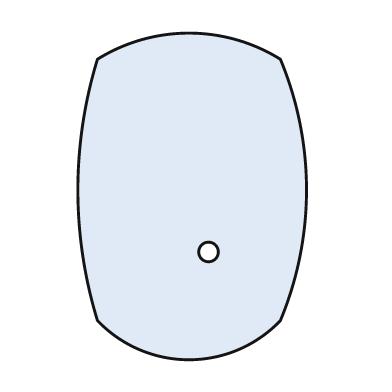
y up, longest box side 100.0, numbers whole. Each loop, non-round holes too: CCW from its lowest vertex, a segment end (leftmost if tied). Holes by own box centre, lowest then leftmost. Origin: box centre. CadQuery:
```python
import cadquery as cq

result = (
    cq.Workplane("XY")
    .moveTo(-29.0, -38.0)
    .threePointArc((-1.0, -50.0), (27.0, -38.0))
    .threePointArc((35.0, 2.0), (27.0, 42.0))
    .threePointArc((-1.0, 50.0), (-29.0, 42.0))
    .threePointArc((-35.0, 2.0), (-29.0, -38.0))
    .close()
    .moveTo(5.0, -17.0)
    .circle(3.0)
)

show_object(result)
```